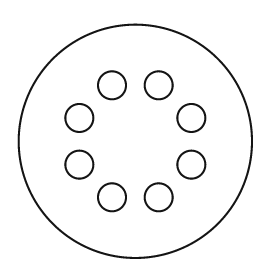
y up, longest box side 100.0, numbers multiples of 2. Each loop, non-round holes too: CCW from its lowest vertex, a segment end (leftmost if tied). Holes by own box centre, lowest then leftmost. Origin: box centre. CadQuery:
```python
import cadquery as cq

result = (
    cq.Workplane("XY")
    .moveTo(0.0, 0.0)
    .circle(50.0)
    .moveTo(-10.0, -24.0)
    .circle(6.0)
    .moveTo(10.0, -24.0)
    .circle(6.0)
    .moveTo(-24.0, -10.0)
    .circle(6.0)
    .moveTo(24.0, -10.0)
    .circle(6.0)
    .moveTo(-24.0, 10.0)
    .circle(6.0)
    .moveTo(24.0, 10.0)
    .circle(6.0)
    .moveTo(-10.0, 24.0)
    .circle(6.0)
    .moveTo(10.0, 24.0)
    .circle(6.0)
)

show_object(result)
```